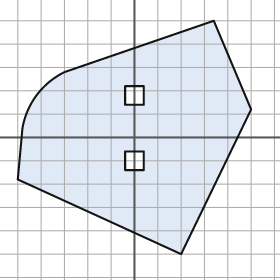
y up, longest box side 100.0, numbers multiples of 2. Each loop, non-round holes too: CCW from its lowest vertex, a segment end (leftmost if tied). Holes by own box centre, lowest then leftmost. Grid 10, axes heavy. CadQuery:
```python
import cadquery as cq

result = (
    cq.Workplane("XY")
    .moveTo(20.0, -50.0)
    .lineTo(50.0, 12.0)
    .lineTo(34.0, 50.0)
    .lineTo(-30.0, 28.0)
    .threePointArc((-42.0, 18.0), (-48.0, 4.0))
    .lineTo(-50.0, -18.0)
    .close()
    .moveTo(-4.0, -14.0)
    .lineTo(4.0, -14.0)
    .lineTo(4.0, -6.0)
    .lineTo(-4.0, -6.0)
    .close()
    .moveTo(-4.0, 14.0)
    .lineTo(4.0, 14.0)
    .lineTo(4.0, 22.0)
    .lineTo(-4.0, 22.0)
    .close()
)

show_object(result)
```